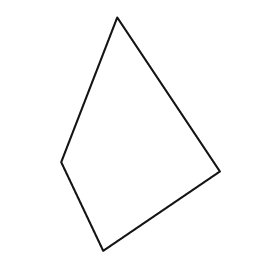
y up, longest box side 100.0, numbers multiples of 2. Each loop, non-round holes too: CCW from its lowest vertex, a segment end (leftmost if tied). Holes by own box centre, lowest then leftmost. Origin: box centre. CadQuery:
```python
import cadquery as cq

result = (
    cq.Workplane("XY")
    .moveTo(-16.0, -50.0)
    .lineTo(34.0, -16.0)
    .lineTo(-10.0, 50.0)
    .lineTo(-34.0, -12.0)
    .close()
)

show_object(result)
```